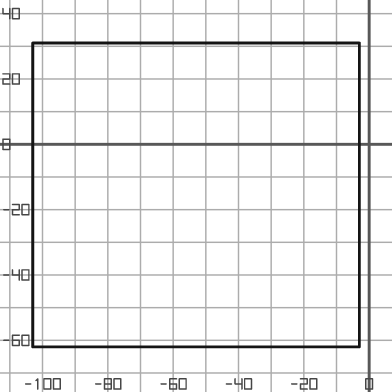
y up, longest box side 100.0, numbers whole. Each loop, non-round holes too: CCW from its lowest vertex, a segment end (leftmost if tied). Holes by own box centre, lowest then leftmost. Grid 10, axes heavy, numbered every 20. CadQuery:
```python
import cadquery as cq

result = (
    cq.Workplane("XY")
    .moveTo(-103.0, -62.0)
    .lineTo(-3.0, -62.0)
    .lineTo(-3.0, 31.0)
    .lineTo(-103.0, 31.0)
    .close()
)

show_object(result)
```